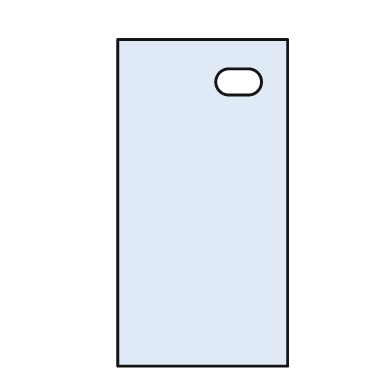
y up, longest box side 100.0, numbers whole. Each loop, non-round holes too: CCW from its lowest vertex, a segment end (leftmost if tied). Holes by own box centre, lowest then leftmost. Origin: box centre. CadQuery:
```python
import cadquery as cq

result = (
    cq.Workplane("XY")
    .moveTo(-26.0, -50.0)
    .lineTo(26.0, -50.0)
    .lineTo(26.0, 50.0)
    .lineTo(-26.0, 50.0)
    .close()
    .moveTo(8.0, 33.0)
    .lineTo(14.0, 33.0)
    .threePointArc((18.0, 37.0), (14.0, 41.0))
    .lineTo(8.0, 41.0)
    .threePointArc((4.0, 37.0), (8.0, 33.0))
    .close()
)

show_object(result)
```